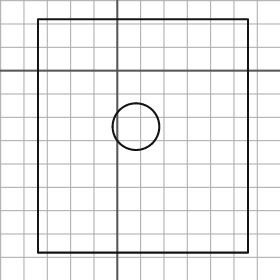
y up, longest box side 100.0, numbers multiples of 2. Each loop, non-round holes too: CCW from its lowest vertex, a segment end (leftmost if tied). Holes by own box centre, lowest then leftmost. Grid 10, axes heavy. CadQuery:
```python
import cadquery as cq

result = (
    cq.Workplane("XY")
    .moveTo(-34.0, -78.0)
    .lineTo(56.0, -78.0)
    .lineTo(56.0, 22.0)
    .lineTo(-34.0, 22.0)
    .close()
    .moveTo(8.0, -24.0)
    .circle(10.0)
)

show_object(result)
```